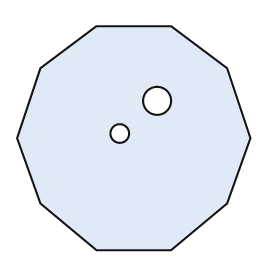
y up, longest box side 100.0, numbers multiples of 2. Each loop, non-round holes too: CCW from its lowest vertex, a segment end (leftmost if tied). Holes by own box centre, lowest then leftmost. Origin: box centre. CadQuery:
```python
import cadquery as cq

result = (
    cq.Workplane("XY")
    .moveTo(-16.0, -48.0)
    .lineTo(16.0, -48.0)
    .lineTo(40.0, -28.0)
    .lineTo(50.0, 0.0)
    .lineTo(40.0, 30.0)
    .lineTo(16.0, 48.0)
    .lineTo(-16.0, 48.0)
    .lineTo(-40.0, 30.0)
    .lineTo(-50.0, 0.0)
    .lineTo(-40.0, -28.0)
    .close()
    .moveTo(-6.0, 2.0)
    .circle(4.0)
    .moveTo(10.0, 16.0)
    .circle(6.0)
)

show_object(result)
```